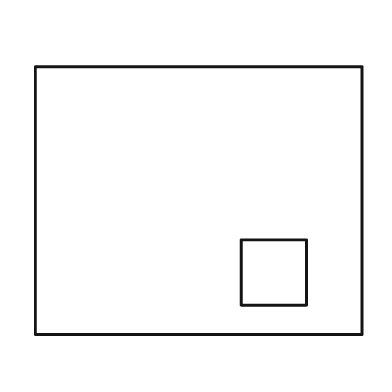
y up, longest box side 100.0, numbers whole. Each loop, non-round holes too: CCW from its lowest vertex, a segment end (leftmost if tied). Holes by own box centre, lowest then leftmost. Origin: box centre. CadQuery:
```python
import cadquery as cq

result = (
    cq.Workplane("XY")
    .moveTo(-50.0, -41.0)
    .lineTo(50.0, -41.0)
    .lineTo(50.0, 41.0)
    .lineTo(-50.0, 41.0)
    .close()
    .moveTo(13.0, -32.0)
    .lineTo(33.0, -32.0)
    .lineTo(33.0, -12.0)
    .lineTo(13.0, -12.0)
    .close()
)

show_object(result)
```